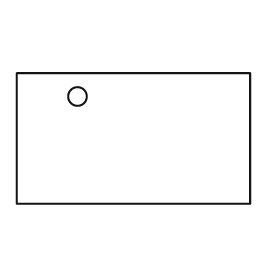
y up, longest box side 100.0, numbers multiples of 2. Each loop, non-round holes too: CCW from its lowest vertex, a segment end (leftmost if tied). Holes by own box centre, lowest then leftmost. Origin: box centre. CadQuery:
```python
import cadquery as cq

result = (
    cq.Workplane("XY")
    .moveTo(-50.0, -28.0)
    .lineTo(50.0, -28.0)
    .lineTo(50.0, 28.0)
    .lineTo(-50.0, 28.0)
    .close()
    .moveTo(-24.0, 18.0)
    .circle(4.0)
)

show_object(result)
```